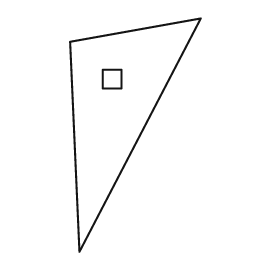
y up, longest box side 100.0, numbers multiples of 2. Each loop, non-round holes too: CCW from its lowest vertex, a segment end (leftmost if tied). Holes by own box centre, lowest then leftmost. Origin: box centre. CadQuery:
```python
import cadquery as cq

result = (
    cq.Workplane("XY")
    .moveTo(-24.0, -50.0)
    .lineTo(28.0, 50.0)
    .lineTo(-28.0, 40.0)
    .close()
    .moveTo(-14.0, 20.0)
    .lineTo(-6.0, 20.0)
    .lineTo(-6.0, 28.0)
    .lineTo(-14.0, 28.0)
    .close()
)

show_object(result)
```